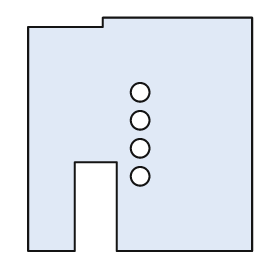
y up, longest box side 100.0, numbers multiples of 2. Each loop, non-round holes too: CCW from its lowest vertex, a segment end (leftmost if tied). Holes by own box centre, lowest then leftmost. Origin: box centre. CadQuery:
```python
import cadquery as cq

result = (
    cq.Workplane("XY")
    .moveTo(-48.0, -50.0)
    .lineTo(-28.0, -50.0)
    .lineTo(-28.0, -12.0)
    .lineTo(-10.0, -12.0)
    .lineTo(-10.0, -50.0)
    .lineTo(48.0, -50.0)
    .lineTo(48.0, 50.0)
    .lineTo(-16.0, 50.0)
    .lineTo(-16.0, 46.0)
    .lineTo(-48.0, 46.0)
    .close()
    .moveTo(0.0, -18.0)
    .circle(4.0)
    .moveTo(0.0, -6.0)
    .circle(4.0)
    .moveTo(0.0, 6.0)
    .circle(4.0)
    .moveTo(0.0, 18.0)
    .circle(4.0)
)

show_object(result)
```